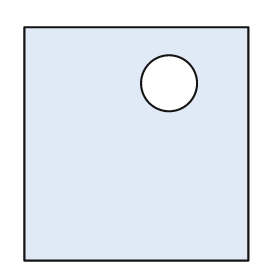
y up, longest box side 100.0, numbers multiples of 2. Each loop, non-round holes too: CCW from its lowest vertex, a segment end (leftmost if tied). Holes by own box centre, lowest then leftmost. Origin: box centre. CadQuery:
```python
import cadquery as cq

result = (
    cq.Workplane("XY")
    .moveTo(-48.0, -50.0)
    .lineTo(48.0, -50.0)
    .lineTo(48.0, 50.0)
    .lineTo(-48.0, 50.0)
    .close()
    .moveTo(14.0, 26.0)
    .circle(12.0)
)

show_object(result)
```